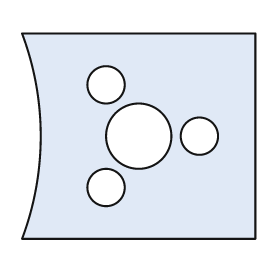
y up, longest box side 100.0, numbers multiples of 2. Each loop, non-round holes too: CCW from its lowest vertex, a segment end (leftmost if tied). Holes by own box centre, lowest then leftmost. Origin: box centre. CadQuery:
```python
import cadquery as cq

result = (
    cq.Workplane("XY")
    .moveTo(-50.0, -44.0)
    .lineTo(50.0, -44.0)
    .lineTo(50.0, 44.0)
    .lineTo(-50.0, 44.0)
    .threePointArc((-42.0, 0.0), (-50.0, -44.0))
    .close()
    .moveTo(-14.0, -22.0)
    .circle(8.0)
    .moveTo(0.0, 0.0)
    .circle(14.0)
    .moveTo(26.0, 0.0)
    .circle(8.0)
    .moveTo(-14.0, 22.0)
    .circle(8.0)
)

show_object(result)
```